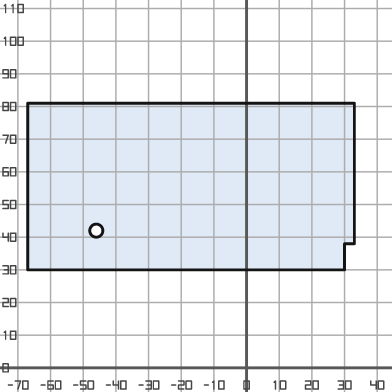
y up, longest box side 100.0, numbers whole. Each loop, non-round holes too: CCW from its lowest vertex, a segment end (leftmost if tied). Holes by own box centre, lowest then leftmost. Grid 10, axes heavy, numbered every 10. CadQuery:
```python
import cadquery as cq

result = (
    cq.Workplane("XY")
    .moveTo(-67.0, 30.0)
    .lineTo(30.0, 30.0)
    .lineTo(30.0, 38.0)
    .lineTo(33.0, 38.0)
    .lineTo(33.0, 81.0)
    .lineTo(-67.0, 81.0)
    .close()
    .moveTo(-46.0, 42.0)
    .circle(2.0)
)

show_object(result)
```